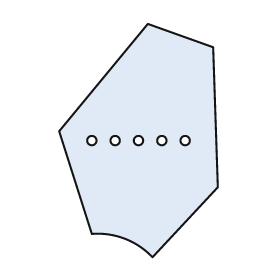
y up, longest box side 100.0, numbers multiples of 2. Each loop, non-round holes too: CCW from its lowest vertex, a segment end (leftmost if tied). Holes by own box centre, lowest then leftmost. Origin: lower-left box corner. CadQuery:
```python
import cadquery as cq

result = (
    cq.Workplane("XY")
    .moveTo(40.0, 0.0)
    .lineTo(68.0, 30.0)
    .lineTo(66.0, 90.0)
    .lineTo(38.0, 100.0)
    .lineTo(0.0, 54.0)
    .lineTo(14.0, 10.0)
    .threePointArc((28.0, 8.0), (40.0, 0.0))
    .close()
    .moveTo(14.0, 50.0)
    .circle(2.0)
    .moveTo(24.0, 50.0)
    .circle(2.0)
    .moveTo(34.0, 50.0)
    .circle(2.0)
    .moveTo(44.0, 50.0)
    .circle(2.0)
    .moveTo(54.0, 50.0)
    .circle(2.0)
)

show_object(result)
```